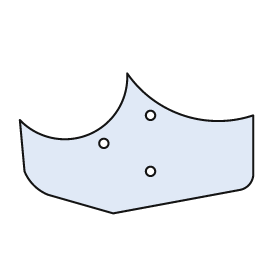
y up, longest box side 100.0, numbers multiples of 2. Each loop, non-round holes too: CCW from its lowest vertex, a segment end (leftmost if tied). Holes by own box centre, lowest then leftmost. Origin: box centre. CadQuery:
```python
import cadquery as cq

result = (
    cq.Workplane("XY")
    .moveTo(-10.0, -30.0)
    .lineTo(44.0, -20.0)
    .threePointArc((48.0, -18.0), (50.0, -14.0))
    .lineTo(50.0, 12.0)
    .threePointArc((20.0, 12.0), (-4.0, 30.0))
    .threePointArc((-20.0, 4.0), (-50.0, 10.0))
    .lineTo(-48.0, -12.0)
    .threePointArc((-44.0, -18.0), (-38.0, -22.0))
    .close()
    .moveTo(6.0, -12.0)
    .circle(2.0)
    .moveTo(-14.0, 0.0)
    .circle(2.0)
    .moveTo(6.0, 12.0)
    .circle(2.0)
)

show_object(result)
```